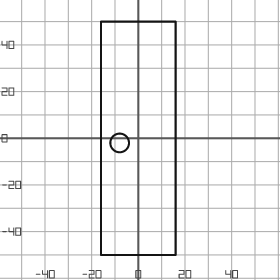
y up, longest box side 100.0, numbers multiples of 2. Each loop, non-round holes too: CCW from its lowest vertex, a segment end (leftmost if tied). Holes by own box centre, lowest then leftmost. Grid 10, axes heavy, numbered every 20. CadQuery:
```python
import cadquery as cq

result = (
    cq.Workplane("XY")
    .moveTo(-16.0, -50.0)
    .lineTo(16.0, -50.0)
    .lineTo(16.0, 50.0)
    .lineTo(-16.0, 50.0)
    .close()
    .moveTo(-8.0, -2.0)
    .circle(4.0)
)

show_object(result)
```